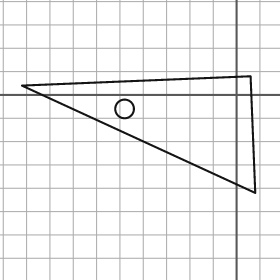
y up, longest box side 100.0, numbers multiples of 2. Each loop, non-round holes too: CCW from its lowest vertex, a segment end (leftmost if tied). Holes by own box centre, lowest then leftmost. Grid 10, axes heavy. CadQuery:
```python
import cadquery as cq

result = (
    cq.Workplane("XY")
    .moveTo(8.0, -42.0)
    .lineTo(6.0, 8.0)
    .lineTo(-92.0, 4.0)
    .close()
    .moveTo(-48.0, -6.0)
    .circle(4.0)
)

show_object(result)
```